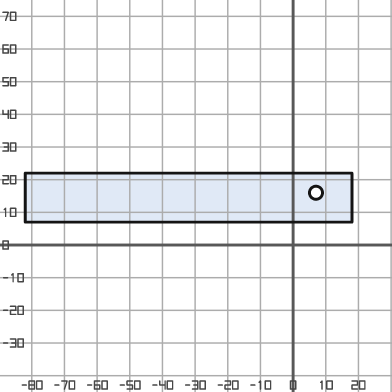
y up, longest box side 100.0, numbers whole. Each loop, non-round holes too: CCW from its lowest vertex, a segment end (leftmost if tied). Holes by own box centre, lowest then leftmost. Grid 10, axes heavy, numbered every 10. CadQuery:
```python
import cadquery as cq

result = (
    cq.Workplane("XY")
    .moveTo(-82.0, 7.0)
    .lineTo(18.0, 7.0)
    .lineTo(18.0, 22.0)
    .lineTo(-82.0, 22.0)
    .close()
    .moveTo(7.0, 16.0)
    .circle(2.0)
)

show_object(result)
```